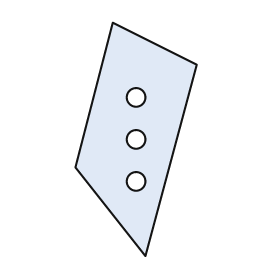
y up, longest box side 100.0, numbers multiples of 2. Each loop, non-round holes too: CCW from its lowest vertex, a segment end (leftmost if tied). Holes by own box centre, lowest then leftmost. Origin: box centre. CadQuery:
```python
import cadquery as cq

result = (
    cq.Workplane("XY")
    .moveTo(4.0, -50.0)
    .lineTo(26.0, 32.0)
    .lineTo(-10.0, 50.0)
    .lineTo(-26.0, -12.0)
    .close()
    .moveTo(0.0, -18.0)
    .circle(4.0)
    .moveTo(0.0, 0.0)
    .circle(4.0)
    .moveTo(0.0, 18.0)
    .circle(4.0)
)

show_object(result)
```